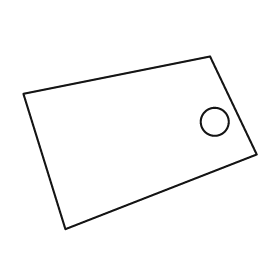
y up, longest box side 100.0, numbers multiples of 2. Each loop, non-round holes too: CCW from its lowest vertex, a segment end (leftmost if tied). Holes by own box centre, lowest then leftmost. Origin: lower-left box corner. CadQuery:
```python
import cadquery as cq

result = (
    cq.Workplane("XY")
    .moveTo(18.0, 0.0)
    .lineTo(100.0, 32.0)
    .lineTo(80.0, 74.0)
    .lineTo(0.0, 58.0)
    .close()
    .moveTo(82.0, 46.0)
    .circle(6.0)
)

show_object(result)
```